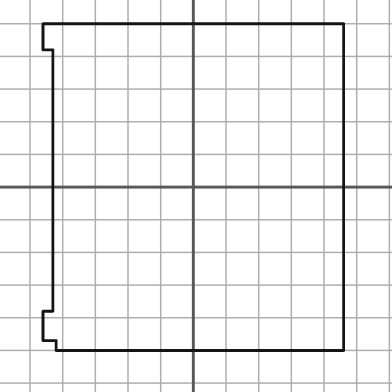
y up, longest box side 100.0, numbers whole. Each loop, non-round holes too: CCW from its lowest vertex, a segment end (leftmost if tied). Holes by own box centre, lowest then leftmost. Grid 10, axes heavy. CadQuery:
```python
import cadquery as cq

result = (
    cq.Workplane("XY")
    .moveTo(-42.0, -50.0)
    .lineTo(46.0, -50.0)
    .lineTo(46.0, 50.0)
    .lineTo(-46.0, 50.0)
    .lineTo(-46.0, 42.0)
    .lineTo(-43.0, 42.0)
    .lineTo(-43.0, -38.0)
    .lineTo(-46.0, -38.0)
    .lineTo(-46.0, -47.0)
    .lineTo(-42.0, -47.0)
    .close()
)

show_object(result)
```